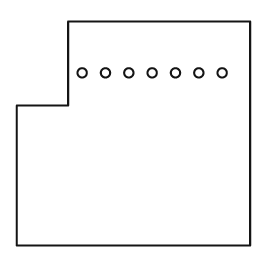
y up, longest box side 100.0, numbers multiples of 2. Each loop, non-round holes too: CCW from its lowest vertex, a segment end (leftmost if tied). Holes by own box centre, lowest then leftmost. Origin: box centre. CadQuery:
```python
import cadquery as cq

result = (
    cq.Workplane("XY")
    .moveTo(-50.0, -48.0)
    .lineTo(50.0, -48.0)
    .lineTo(50.0, 48.0)
    .lineTo(-28.0, 48.0)
    .lineTo(-28.0, 12.0)
    .lineTo(-50.0, 12.0)
    .close()
    .moveTo(-22.0, 26.0)
    .circle(2.0)
    .moveTo(-12.0, 26.0)
    .circle(2.0)
    .moveTo(-2.0, 26.0)
    .circle(2.0)
    .moveTo(8.0, 26.0)
    .circle(2.0)
    .moveTo(18.0, 26.0)
    .circle(2.0)
    .moveTo(28.0, 26.0)
    .circle(2.0)
    .moveTo(38.0, 26.0)
    .circle(2.0)
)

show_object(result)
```